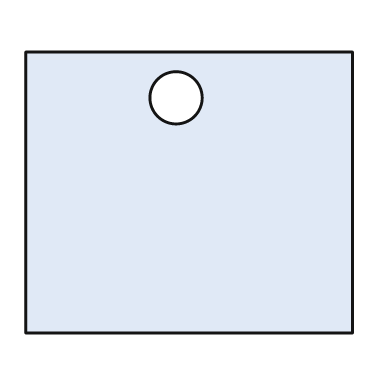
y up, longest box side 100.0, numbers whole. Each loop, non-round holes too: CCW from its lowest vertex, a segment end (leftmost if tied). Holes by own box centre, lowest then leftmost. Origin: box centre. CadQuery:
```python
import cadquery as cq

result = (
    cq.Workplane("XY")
    .moveTo(-50.0, -43.0)
    .lineTo(50.0, -43.0)
    .lineTo(50.0, 43.0)
    .lineTo(-50.0, 43.0)
    .close()
    .moveTo(-4.0, 29.0)
    .circle(8.0)
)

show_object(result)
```